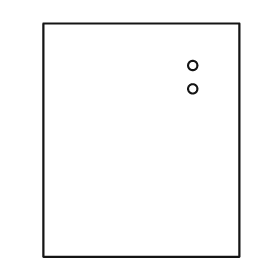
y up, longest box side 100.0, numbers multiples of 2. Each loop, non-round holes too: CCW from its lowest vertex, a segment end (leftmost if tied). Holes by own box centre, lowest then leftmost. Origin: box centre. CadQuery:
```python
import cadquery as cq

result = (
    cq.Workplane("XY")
    .moveTo(-42.0, -50.0)
    .lineTo(42.0, -50.0)
    .lineTo(42.0, 50.0)
    .lineTo(-42.0, 50.0)
    .close()
    .moveTo(22.0, 22.0)
    .circle(2.0)
    .moveTo(22.0, 32.0)
    .circle(2.0)
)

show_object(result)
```